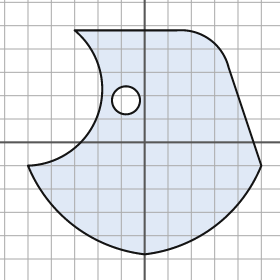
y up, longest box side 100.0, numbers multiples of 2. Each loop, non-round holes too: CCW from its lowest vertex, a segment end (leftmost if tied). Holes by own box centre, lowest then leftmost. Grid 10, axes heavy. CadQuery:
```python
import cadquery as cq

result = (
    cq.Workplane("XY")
    .moveTo(0.0, -48.0)
    .threePointArc((30.0, -36.0), (50.0, -10.0))
    .lineTo(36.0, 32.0)
    .threePointArc((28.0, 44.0), (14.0, 48.0))
    .lineTo(-30.0, 48.0)
    .threePointArc((-20.0, 12.0), (-50.0, -10.0))
    .threePointArc((-30.0, -36.0), (0.0, -48.0))
    .close()
    .moveTo(-8.0, 18.0)
    .circle(6.0)
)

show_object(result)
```